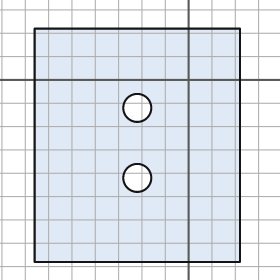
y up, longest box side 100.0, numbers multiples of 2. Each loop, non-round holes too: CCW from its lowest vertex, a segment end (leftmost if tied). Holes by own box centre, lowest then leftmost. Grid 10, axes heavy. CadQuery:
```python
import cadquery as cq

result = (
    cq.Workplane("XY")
    .moveTo(-66.0, -78.0)
    .lineTo(22.0, -78.0)
    .lineTo(22.0, 22.0)
    .lineTo(-66.0, 22.0)
    .close()
    .moveTo(-22.0, -42.0)
    .circle(6.0)
    .moveTo(-22.0, -12.0)
    .circle(6.0)
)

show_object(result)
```